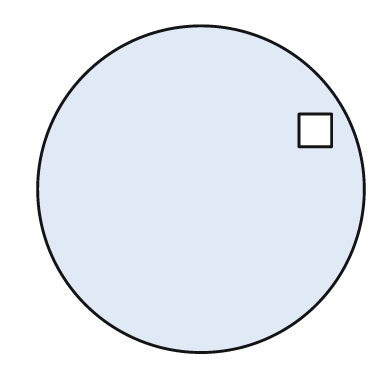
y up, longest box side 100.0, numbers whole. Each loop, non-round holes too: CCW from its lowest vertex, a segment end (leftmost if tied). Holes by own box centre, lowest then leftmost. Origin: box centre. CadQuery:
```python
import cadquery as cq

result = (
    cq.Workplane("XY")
    .moveTo(0.0, 0.0)
    .circle(50.0)
    .moveTo(30.0, 13.0)
    .lineTo(40.0, 13.0)
    .lineTo(40.0, 23.0)
    .lineTo(30.0, 23.0)
    .close()
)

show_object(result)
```